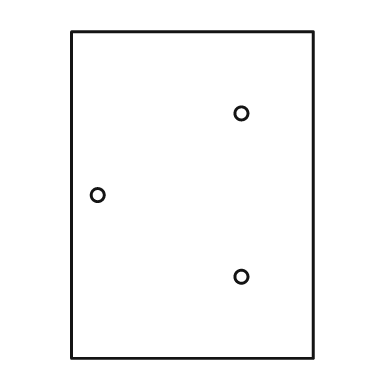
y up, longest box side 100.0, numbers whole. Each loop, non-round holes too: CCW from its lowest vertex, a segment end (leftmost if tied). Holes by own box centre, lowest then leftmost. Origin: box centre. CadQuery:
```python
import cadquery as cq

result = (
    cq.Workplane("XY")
    .moveTo(-37.0, -50.0)
    .lineTo(37.0, -50.0)
    .lineTo(37.0, 50.0)
    .lineTo(-37.0, 50.0)
    .close()
    .moveTo(15.0, -25.0)
    .circle(2.0)
    .moveTo(-29.0, 0.0)
    .circle(2.0)
    .moveTo(15.0, 25.0)
    .circle(2.0)
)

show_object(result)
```